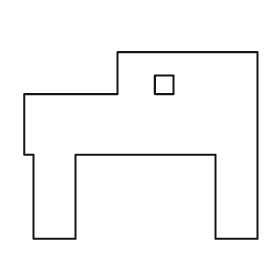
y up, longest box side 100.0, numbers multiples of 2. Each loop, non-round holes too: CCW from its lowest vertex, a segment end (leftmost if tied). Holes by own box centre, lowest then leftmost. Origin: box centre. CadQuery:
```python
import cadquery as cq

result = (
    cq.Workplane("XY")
    .moveTo(-46.0, -40.0)
    .lineTo(-28.0, -40.0)
    .lineTo(-28.0, -4.0)
    .lineTo(32.0, -4.0)
    .lineTo(32.0, -40.0)
    .lineTo(50.0, -40.0)
    .lineTo(50.0, 40.0)
    .lineTo(-10.0, 40.0)
    .lineTo(-10.0, 22.0)
    .lineTo(-50.0, 22.0)
    .lineTo(-50.0, -4.0)
    .lineTo(-46.0, -4.0)
    .close()
    .moveTo(6.0, 22.0)
    .lineTo(14.0, 22.0)
    .lineTo(14.0, 30.0)
    .lineTo(6.0, 30.0)
    .close()
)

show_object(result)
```